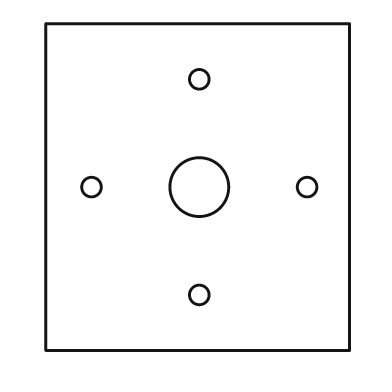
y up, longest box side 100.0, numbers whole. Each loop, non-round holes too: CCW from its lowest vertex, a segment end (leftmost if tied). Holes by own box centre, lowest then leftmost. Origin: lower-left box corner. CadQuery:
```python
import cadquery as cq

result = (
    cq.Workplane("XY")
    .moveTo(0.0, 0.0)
    .lineTo(93.0, 0.0)
    .lineTo(93.0, 100.0)
    .lineTo(0.0, 100.0)
    .close()
    .moveTo(47.0, 17.0)
    .circle(3.0)
    .moveTo(14.0, 50.0)
    .circle(3.0)
    .moveTo(47.0, 50.0)
    .circle(9.0)
    .moveTo(80.0, 50.0)
    .circle(3.0)
    .moveTo(47.0, 83.0)
    .circle(3.0)
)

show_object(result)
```